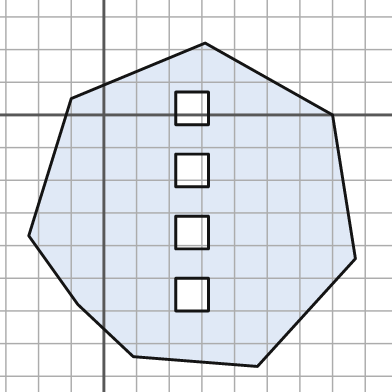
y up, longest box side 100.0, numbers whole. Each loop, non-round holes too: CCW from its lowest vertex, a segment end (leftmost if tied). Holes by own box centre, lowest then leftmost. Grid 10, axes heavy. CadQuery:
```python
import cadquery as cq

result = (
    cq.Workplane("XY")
    .moveTo(47.0, -77.0)
    .lineTo(77.0, -44.0)
    .lineTo(70.0, 0.0)
    .lineTo(31.0, 22.0)
    .lineTo(-10.0, 5.0)
    .lineTo(-23.0, -37.0)
    .lineTo(-8.0, -58.0)
    .lineTo(9.0, -74.0)
    .close()
    .moveTo(22.0, -60.0)
    .lineTo(32.0, -60.0)
    .lineTo(32.0, -50.0)
    .lineTo(22.0, -50.0)
    .close()
    .moveTo(22.0, -41.0)
    .lineTo(32.0, -41.0)
    .lineTo(32.0, -31.0)
    .lineTo(22.0, -31.0)
    .close()
    .moveTo(22.0, -22.0)
    .lineTo(32.0, -22.0)
    .lineTo(32.0, -12.0)
    .lineTo(22.0, -12.0)
    .close()
    .moveTo(22.0, -3.0)
    .lineTo(32.0, -3.0)
    .lineTo(32.0, 7.0)
    .lineTo(22.0, 7.0)
    .close()
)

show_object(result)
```